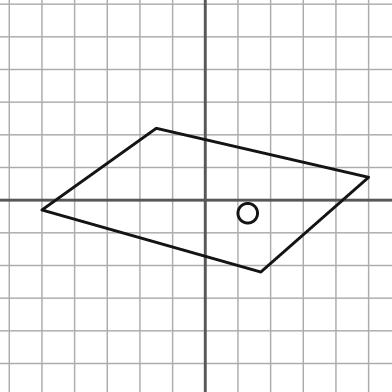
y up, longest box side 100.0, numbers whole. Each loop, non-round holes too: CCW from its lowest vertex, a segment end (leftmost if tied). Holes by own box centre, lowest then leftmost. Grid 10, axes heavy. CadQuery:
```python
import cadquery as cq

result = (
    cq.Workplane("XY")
    .moveTo(17.0, -22.0)
    .lineTo(50.0, 7.0)
    .lineTo(-15.0, 22.0)
    .lineTo(-50.0, -3.0)
    .close()
    .moveTo(13.0, -4.0)
    .circle(3.0)
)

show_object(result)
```